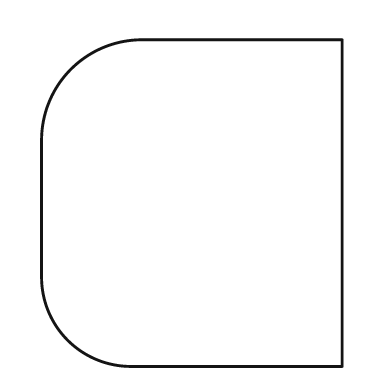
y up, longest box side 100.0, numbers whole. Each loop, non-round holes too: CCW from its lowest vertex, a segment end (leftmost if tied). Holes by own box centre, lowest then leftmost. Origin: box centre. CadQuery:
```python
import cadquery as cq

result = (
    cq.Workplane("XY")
    .moveTo(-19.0, -50.0)
    .lineTo(46.0, -50.0)
    .lineTo(46.0, 50.0)
    .lineTo(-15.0, 50.0)
    .threePointArc((-37.0, 41.0), (-46.0, 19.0))
    .lineTo(-46.0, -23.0)
    .threePointArc((-38.0, -42.0), (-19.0, -50.0))
    .close()
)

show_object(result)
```